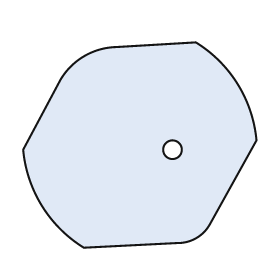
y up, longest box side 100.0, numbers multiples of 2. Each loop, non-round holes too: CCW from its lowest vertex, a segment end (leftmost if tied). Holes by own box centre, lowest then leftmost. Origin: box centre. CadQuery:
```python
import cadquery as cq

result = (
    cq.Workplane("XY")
    .moveTo(-24.0, -44.0)
    .lineTo(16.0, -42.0)
    .threePointArc((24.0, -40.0), (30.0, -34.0))
    .lineTo(50.0, 2.0)
    .threePointArc((42.0, 26.0), (24.0, 44.0))
    .lineTo(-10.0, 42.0)
    .threePointArc((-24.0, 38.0), (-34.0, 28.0))
    .lineTo(-50.0, -2.0)
    .threePointArc((-42.0, -26.0), (-24.0, -44.0))
    .close()
    .moveTo(14.0, -2.0)
    .circle(4.0)
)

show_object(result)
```